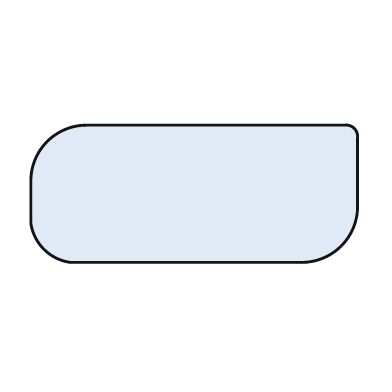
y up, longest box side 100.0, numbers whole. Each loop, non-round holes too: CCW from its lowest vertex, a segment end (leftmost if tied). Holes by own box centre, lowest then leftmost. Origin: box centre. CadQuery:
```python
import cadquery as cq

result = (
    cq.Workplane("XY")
    .moveTo(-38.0, -21.0)
    .lineTo(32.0, -21.0)
    .threePointArc((45.0, -16.0), (50.0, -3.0))
    .lineTo(50.0, 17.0)
    .threePointArc((49.0, 20.0), (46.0, 21.0))
    .lineTo(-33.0, 21.0)
    .threePointArc((-45.0, 16.0), (-50.0, 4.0))
    .lineTo(-50.0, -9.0)
    .threePointArc((-46.0, -17.0), (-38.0, -21.0))
    .close()
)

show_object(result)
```